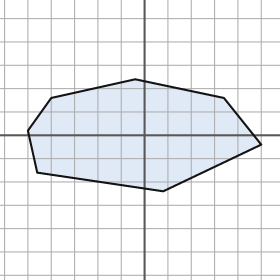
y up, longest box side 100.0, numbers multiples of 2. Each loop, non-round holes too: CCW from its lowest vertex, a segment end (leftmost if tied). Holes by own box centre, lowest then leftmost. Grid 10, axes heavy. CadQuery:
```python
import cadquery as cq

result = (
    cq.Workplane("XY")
    .moveTo(8.0, -24.0)
    .lineTo(50.0, -4.0)
    .lineTo(34.0, 16.0)
    .lineTo(-4.0, 24.0)
    .lineTo(-40.0, 16.0)
    .lineTo(-50.0, 2.0)
    .lineTo(-46.0, -16.0)
    .close()
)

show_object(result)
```